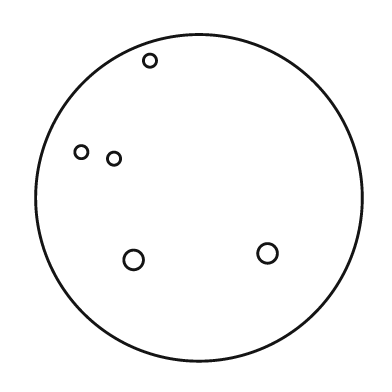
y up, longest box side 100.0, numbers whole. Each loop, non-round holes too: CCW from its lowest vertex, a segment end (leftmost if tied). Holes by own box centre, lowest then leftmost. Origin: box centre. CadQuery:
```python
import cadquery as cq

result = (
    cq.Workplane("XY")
    .moveTo(0.0, 0.0)
    .circle(50.0)
    .moveTo(-20.0, -19.0)
    .circle(3.0)
    .moveTo(21.0, -17.0)
    .circle(3.0)
    .moveTo(-26.0, 12.0)
    .circle(2.0)
    .moveTo(-36.0, 14.0)
    .circle(2.0)
    .moveTo(-15.0, 42.0)
    .circle(2.0)
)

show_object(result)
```